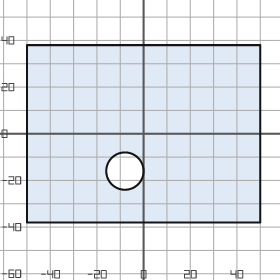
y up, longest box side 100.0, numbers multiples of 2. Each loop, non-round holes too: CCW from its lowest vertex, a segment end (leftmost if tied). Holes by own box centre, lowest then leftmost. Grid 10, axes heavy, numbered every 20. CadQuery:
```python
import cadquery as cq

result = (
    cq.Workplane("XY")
    .moveTo(-50.0, -38.0)
    .lineTo(50.0, -38.0)
    .lineTo(50.0, 38.0)
    .lineTo(-50.0, 38.0)
    .close()
    .moveTo(-8.0, -16.0)
    .circle(8.0)
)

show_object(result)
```